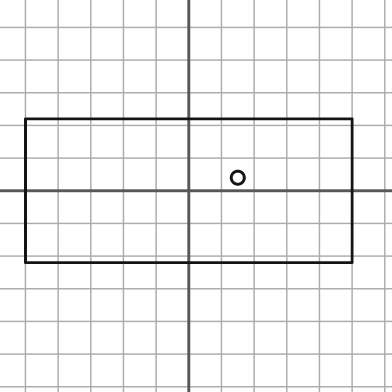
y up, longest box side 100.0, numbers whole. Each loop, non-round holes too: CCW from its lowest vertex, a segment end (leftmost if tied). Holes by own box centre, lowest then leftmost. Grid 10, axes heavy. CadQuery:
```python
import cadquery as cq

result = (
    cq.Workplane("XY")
    .moveTo(-50.0, -22.0)
    .lineTo(50.0, -22.0)
    .lineTo(50.0, 22.0)
    .lineTo(-50.0, 22.0)
    .close()
    .moveTo(15.0, 4.0)
    .circle(2.0)
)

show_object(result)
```